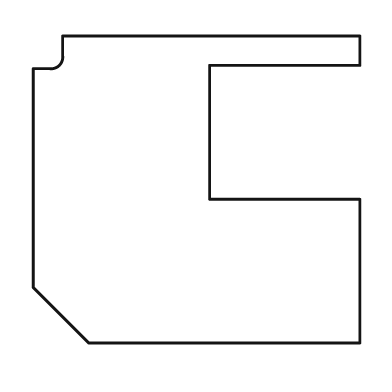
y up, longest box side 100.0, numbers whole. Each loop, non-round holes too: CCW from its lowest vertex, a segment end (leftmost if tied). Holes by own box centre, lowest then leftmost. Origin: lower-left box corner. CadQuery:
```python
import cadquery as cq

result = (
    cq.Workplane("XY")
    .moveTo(17.0, 0.0)
    .lineTo(100.0, 0.0)
    .lineTo(100.0, 44.0)
    .lineTo(54.0, 44.0)
    .lineTo(54.0, 85.0)
    .lineTo(100.0, 85.0)
    .lineTo(100.0, 94.0)
    .lineTo(9.0, 94.0)
    .lineTo(9.0, 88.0)
    .threePointArc((8.0, 85.0), (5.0, 84.0))
    .lineTo(0.0, 84.0)
    .lineTo(0.0, 17.0)
    .close()
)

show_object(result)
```